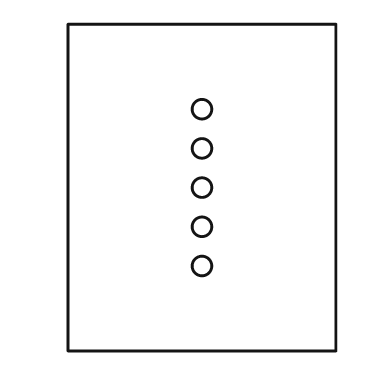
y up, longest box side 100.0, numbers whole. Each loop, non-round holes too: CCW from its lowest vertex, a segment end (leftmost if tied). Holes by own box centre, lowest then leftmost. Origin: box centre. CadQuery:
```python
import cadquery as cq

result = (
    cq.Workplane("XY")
    .moveTo(-41.0, -50.0)
    .lineTo(41.0, -50.0)
    .lineTo(41.0, 50.0)
    .lineTo(-41.0, 50.0)
    .close()
    .moveTo(0.0, -24.0)
    .circle(3.0)
    .moveTo(0.0, -12.0)
    .circle(3.0)
    .moveTo(0.0, 0.0)
    .circle(3.0)
    .moveTo(0.0, 12.0)
    .circle(3.0)
    .moveTo(0.0, 24.0)
    .circle(3.0)
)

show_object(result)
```